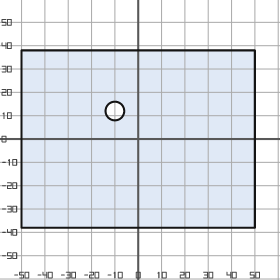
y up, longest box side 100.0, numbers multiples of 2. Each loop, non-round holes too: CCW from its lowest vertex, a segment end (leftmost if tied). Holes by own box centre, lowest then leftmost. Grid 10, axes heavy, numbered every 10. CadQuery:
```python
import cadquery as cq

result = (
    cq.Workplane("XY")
    .moveTo(-50.0, -38.0)
    .lineTo(50.0, -38.0)
    .lineTo(50.0, 38.0)
    .lineTo(-50.0, 38.0)
    .close()
    .moveTo(-10.0, 12.0)
    .circle(4.0)
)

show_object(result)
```